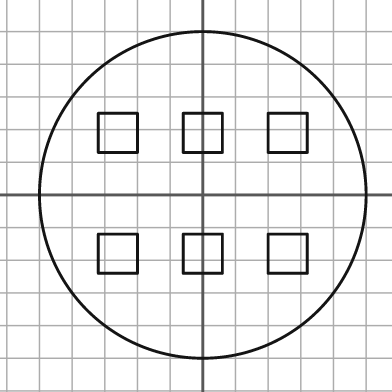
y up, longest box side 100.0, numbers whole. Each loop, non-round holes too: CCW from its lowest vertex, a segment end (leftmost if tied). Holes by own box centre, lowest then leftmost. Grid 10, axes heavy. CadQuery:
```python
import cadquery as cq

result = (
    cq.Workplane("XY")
    .moveTo(0.0, 0.0)
    .circle(50.0)
    .moveTo(-32.0, -24.0)
    .lineTo(-20.0, -24.0)
    .lineTo(-20.0, -12.0)
    .lineTo(-32.0, -12.0)
    .close()
    .moveTo(-6.0, -24.0)
    .lineTo(6.0, -24.0)
    .lineTo(6.0, -12.0)
    .lineTo(-6.0, -12.0)
    .close()
    .moveTo(20.0, -24.0)
    .lineTo(32.0, -24.0)
    .lineTo(32.0, -12.0)
    .lineTo(20.0, -12.0)
    .close()
    .moveTo(-32.0, 13.0)
    .lineTo(-20.0, 13.0)
    .lineTo(-20.0, 25.0)
    .lineTo(-32.0, 25.0)
    .close()
    .moveTo(-6.0, 13.0)
    .lineTo(6.0, 13.0)
    .lineTo(6.0, 25.0)
    .lineTo(-6.0, 25.0)
    .close()
    .moveTo(20.0, 13.0)
    .lineTo(32.0, 13.0)
    .lineTo(32.0, 25.0)
    .lineTo(20.0, 25.0)
    .close()
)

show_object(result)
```